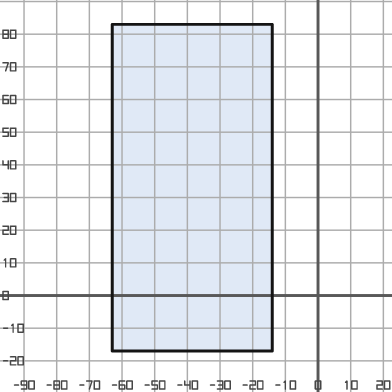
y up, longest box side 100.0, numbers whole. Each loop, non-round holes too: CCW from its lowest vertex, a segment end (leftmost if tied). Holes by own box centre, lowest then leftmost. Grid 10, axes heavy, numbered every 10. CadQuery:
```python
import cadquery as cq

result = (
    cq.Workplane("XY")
    .moveTo(-63.0, -17.0)
    .lineTo(-14.0, -17.0)
    .lineTo(-14.0, 83.0)
    .lineTo(-63.0, 83.0)
    .close()
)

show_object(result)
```